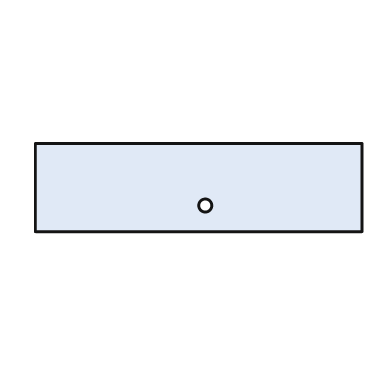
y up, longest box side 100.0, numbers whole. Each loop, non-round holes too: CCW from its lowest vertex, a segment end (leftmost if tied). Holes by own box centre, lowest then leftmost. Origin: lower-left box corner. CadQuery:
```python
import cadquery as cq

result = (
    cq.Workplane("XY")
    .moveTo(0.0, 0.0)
    .lineTo(100.0, 0.0)
    .lineTo(100.0, 27.0)
    .lineTo(0.0, 27.0)
    .close()
    .moveTo(52.0, 8.0)
    .circle(2.0)
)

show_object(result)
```